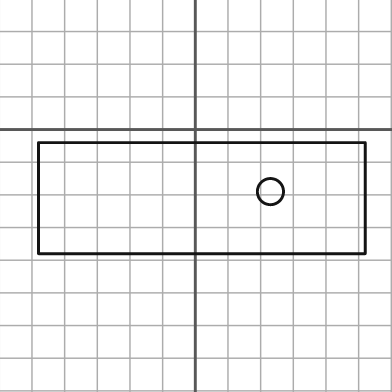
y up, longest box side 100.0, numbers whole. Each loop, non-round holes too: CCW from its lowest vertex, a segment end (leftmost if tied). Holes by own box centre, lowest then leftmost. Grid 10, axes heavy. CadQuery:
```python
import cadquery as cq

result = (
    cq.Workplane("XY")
    .moveTo(-48.0, -38.0)
    .lineTo(52.0, -38.0)
    .lineTo(52.0, -4.0)
    .lineTo(-48.0, -4.0)
    .close()
    .moveTo(23.0, -19.0)
    .circle(4.0)
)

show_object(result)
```